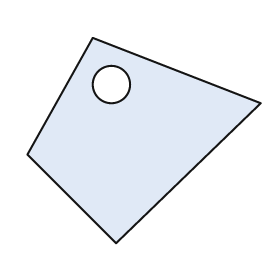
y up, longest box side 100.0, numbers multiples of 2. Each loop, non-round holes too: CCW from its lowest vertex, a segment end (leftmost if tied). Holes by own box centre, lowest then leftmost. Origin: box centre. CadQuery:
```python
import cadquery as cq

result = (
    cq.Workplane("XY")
    .moveTo(-12.0, -44.0)
    .lineTo(50.0, 16.0)
    .lineTo(-22.0, 44.0)
    .lineTo(-50.0, -6.0)
    .close()
    .moveTo(-14.0, 24.0)
    .circle(8.0)
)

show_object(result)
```